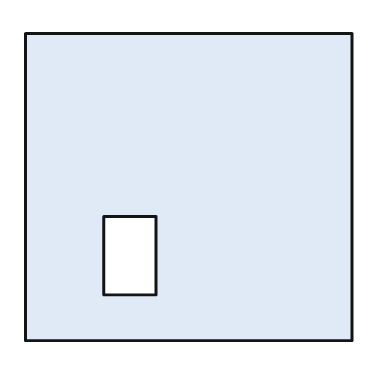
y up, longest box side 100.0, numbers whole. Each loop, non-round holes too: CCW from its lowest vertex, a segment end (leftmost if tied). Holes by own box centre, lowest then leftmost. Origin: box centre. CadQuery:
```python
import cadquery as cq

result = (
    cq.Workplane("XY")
    .moveTo(-50.0, -47.0)
    .lineTo(50.0, -47.0)
    .lineTo(50.0, 47.0)
    .lineTo(-50.0, 47.0)
    .close()
    .moveTo(-26.0, -33.0)
    .lineTo(-10.0, -33.0)
    .lineTo(-10.0, -9.0)
    .lineTo(-26.0, -9.0)
    .close()
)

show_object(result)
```